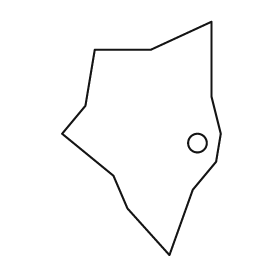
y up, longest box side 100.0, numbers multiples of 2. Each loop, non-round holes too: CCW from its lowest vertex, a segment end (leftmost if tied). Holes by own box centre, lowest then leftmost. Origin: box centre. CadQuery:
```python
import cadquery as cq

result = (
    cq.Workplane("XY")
    .moveTo(12.0, -50.0)
    .lineTo(22.0, -22.0)
    .lineTo(32.0, -10.0)
    .lineTo(34.0, 2.0)
    .lineTo(30.0, 18.0)
    .lineTo(30.0, 50.0)
    .lineTo(4.0, 38.0)
    .lineTo(-20.0, 38.0)
    .lineTo(-24.0, 14.0)
    .lineTo(-34.0, 2.0)
    .lineTo(-12.0, -16.0)
    .lineTo(-6.0, -30.0)
    .close()
    .moveTo(24.0, -2.0)
    .circle(4.0)
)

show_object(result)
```